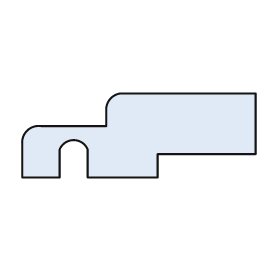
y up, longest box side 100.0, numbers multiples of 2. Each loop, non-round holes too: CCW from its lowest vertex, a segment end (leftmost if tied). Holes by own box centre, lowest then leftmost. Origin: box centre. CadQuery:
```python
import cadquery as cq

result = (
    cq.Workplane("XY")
    .moveTo(-50.0, -18.0)
    .lineTo(-34.0, -18.0)
    .lineTo(-34.0, -6.0)
    .threePointArc((-28.0, -2.0), (-22.0, -6.0))
    .lineTo(-22.0, -18.0)
    .lineTo(8.0, -18.0)
    .lineTo(8.0, -8.0)
    .lineTo(50.0, -8.0)
    .lineTo(50.0, 18.0)
    .lineTo(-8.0, 18.0)
    .threePointArc((-12.0, 16.0), (-14.0, 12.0))
    .lineTo(-14.0, 4.0)
    .lineTo(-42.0, 4.0)
    .threePointArc((-48.0, 2.0), (-50.0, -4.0))
    .close()
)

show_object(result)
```